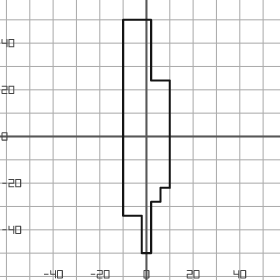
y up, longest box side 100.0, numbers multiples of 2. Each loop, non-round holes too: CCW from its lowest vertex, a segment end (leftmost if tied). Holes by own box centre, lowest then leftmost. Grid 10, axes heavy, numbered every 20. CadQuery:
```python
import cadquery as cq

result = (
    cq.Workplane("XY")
    .moveTo(-2.0, -50.0)
    .lineTo(2.0, -50.0)
    .lineTo(2.0, -28.0)
    .lineTo(6.0, -28.0)
    .lineTo(6.0, -22.0)
    .lineTo(10.0, -22.0)
    .lineTo(10.0, 24.0)
    .lineTo(2.0, 24.0)
    .lineTo(2.0, 50.0)
    .lineTo(-10.0, 50.0)
    .lineTo(-10.0, -34.0)
    .lineTo(-2.0, -34.0)
    .close()
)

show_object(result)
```